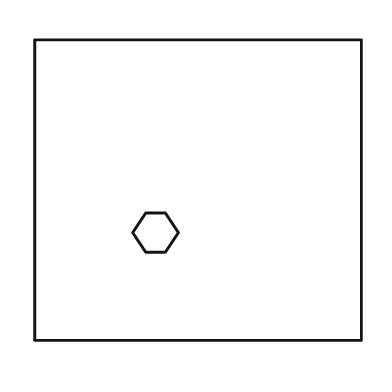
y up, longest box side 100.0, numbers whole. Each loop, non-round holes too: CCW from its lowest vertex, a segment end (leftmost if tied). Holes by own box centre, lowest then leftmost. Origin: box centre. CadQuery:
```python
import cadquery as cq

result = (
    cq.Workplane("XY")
    .moveTo(-50.0, -46.0)
    .lineTo(50.0, -46.0)
    .lineTo(50.0, 46.0)
    .lineTo(-50.0, 46.0)
    .close()
    .moveTo(-16.0, -19.0)
    .lineTo(-10.0, -19.0)
    .lineTo(-6.0, -13.0)
    .lineTo(-10.0, -7.0)
    .lineTo(-16.0, -7.0)
    .lineTo(-20.0, -13.0)
    .close()
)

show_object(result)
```